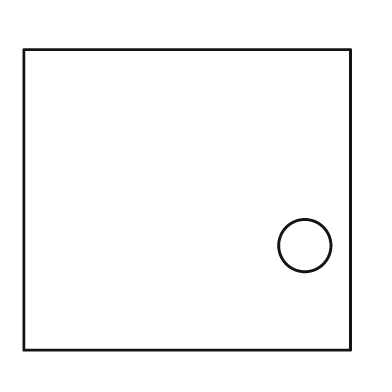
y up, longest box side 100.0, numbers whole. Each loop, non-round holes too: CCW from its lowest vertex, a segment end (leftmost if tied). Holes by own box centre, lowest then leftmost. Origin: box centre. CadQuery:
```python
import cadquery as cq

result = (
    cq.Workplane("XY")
    .moveTo(-50.0, -46.0)
    .lineTo(50.0, -46.0)
    .lineTo(50.0, 46.0)
    .lineTo(-50.0, 46.0)
    .close()
    .moveTo(36.0, -14.0)
    .circle(8.0)
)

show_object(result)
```